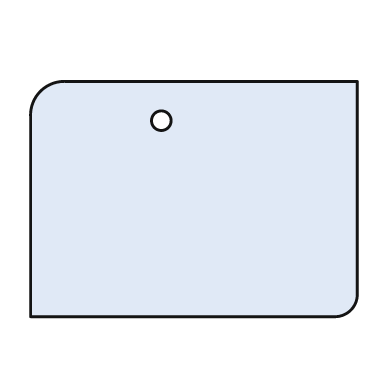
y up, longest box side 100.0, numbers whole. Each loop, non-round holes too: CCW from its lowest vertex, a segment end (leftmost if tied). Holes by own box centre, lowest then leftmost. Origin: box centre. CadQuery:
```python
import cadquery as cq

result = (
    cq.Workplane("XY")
    .moveTo(-50.0, -36.0)
    .lineTo(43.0, -36.0)
    .threePointArc((48.0, -34.0), (50.0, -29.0))
    .lineTo(50.0, 36.0)
    .lineTo(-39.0, 36.0)
    .threePointArc((-47.0, 33.0), (-50.0, 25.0))
    .close()
    .moveTo(-10.0, 24.0)
    .circle(3.0)
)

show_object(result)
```